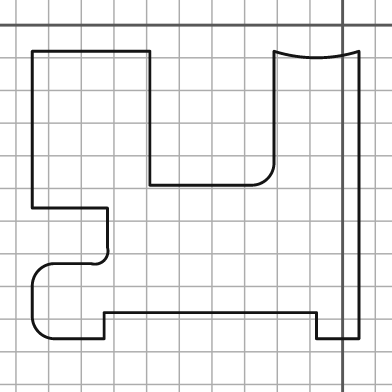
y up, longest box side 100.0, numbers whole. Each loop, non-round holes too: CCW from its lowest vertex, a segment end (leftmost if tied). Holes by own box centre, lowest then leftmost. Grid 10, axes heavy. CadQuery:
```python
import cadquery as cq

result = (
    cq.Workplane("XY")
    .moveTo(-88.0, -96.0)
    .lineTo(-73.0, -96.0)
    .lineTo(-73.0, -88.0)
    .lineTo(-8.0, -88.0)
    .lineTo(-8.0, -96.0)
    .lineTo(5.0, -96.0)
    .lineTo(5.0, -8.0)
    .threePointArc((-8.0, -10.0), (-21.0, -8.0))
    .lineTo(-21.0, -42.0)
    .threePointArc((-23.0, -47.0), (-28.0, -49.0))
    .lineTo(-59.0, -49.0)
    .lineTo(-59.0, -8.0)
    .lineTo(-95.0, -8.0)
    .lineTo(-95.0, -56.0)
    .lineTo(-72.0, -56.0)
    .lineTo(-72.0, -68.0)
    .threePointArc((-73.0, -72.0), (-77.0, -73.0))
    .lineTo(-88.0, -73.0)
    .threePointArc((-93.0, -75.0), (-95.0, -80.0))
    .lineTo(-95.0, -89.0)
    .threePointArc((-93.0, -94.0), (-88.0, -96.0))
    .close()
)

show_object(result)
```